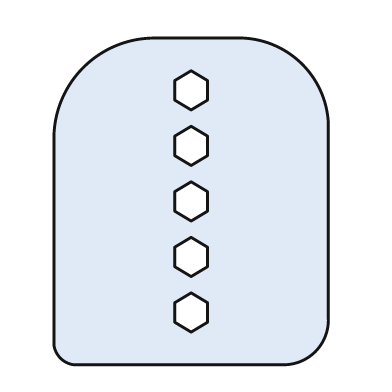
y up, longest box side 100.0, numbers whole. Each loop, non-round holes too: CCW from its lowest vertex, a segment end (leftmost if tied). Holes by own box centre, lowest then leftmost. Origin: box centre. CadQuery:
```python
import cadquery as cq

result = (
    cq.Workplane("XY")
    .moveTo(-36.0, -50.0)
    .lineTo(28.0, -50.0)
    .threePointArc((38.0, -46.0), (42.0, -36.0))
    .lineTo(42.0, 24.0)
    .threePointArc((34.0, 42.0), (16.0, 50.0))
    .lineTo(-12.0, 50.0)
    .threePointArc((-33.0, 41.0), (-42.0, 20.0))
    .lineTo(-42.0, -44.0)
    .threePointArc((-40.0, -48.0), (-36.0, -50.0))
    .close()
    .moveTo(0.0, -40.0)
    .lineTo(5.0, -37.0)
    .lineTo(5.0, -31.0)
    .lineTo(0.0, -28.0)
    .lineTo(-5.0, -31.0)
    .lineTo(-5.0, -37.0)
    .close()
    .moveTo(0.0, -23.0)
    .lineTo(5.0, -20.0)
    .lineTo(5.0, -14.0)
    .lineTo(0.0, -11.0)
    .lineTo(-5.0, -14.0)
    .lineTo(-5.0, -20.0)
    .close()
    .moveTo(0.0, -6.0)
    .lineTo(5.0, -3.0)
    .lineTo(5.0, 3.0)
    .lineTo(0.0, 6.0)
    .lineTo(-5.0, 3.0)
    .lineTo(-5.0, -3.0)
    .close()
    .moveTo(0.0, 11.0)
    .lineTo(5.0, 14.0)
    .lineTo(5.0, 20.0)
    .lineTo(0.0, 23.0)
    .lineTo(-5.0, 20.0)
    .lineTo(-5.0, 14.0)
    .close()
    .moveTo(0.0, 28.0)
    .lineTo(5.0, 31.0)
    .lineTo(5.0, 37.0)
    .lineTo(0.0, 40.0)
    .lineTo(-5.0, 37.0)
    .lineTo(-5.0, 31.0)
    .close()
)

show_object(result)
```